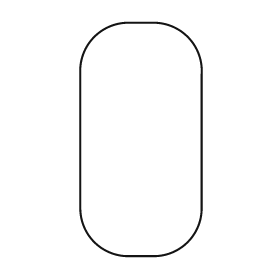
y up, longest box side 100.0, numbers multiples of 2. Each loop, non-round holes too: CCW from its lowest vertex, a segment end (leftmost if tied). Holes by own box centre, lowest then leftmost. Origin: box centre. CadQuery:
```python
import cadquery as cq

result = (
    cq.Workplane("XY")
    .moveTo(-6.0, -50.0)
    .lineTo(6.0, -50.0)
    .threePointArc((20.0, -44.0), (26.0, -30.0))
    .lineTo(26.0, 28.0)
    .threePointArc((20.0, 44.0), (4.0, 50.0))
    .lineTo(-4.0, 50.0)
    .threePointArc((-20.0, 44.0), (-26.0, 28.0))
    .lineTo(-26.0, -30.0)
    .threePointArc((-20.0, -44.0), (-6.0, -50.0))
    .close()
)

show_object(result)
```